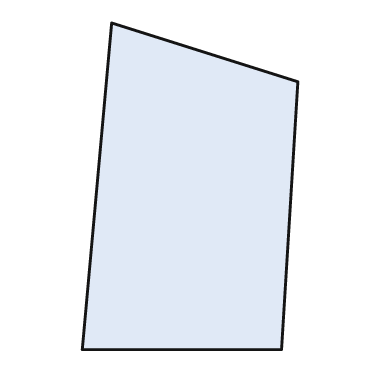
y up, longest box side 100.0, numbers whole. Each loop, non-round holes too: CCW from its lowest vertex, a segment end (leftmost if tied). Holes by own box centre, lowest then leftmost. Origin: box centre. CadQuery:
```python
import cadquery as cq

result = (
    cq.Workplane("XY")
    .moveTo(-33.0, -50.0)
    .lineTo(28.0, -50.0)
    .lineTo(33.0, 32.0)
    .lineTo(-24.0, 50.0)
    .close()
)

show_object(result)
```